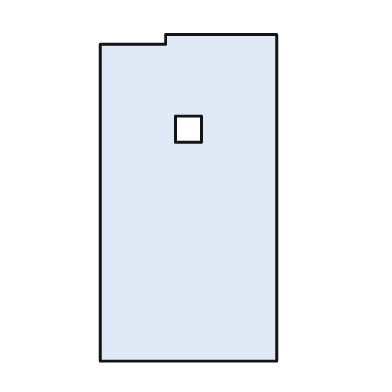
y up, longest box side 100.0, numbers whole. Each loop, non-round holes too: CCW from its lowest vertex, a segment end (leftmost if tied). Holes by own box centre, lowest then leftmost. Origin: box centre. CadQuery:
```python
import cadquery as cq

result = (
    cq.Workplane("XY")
    .moveTo(-27.0, -50.0)
    .lineTo(27.0, -50.0)
    .lineTo(27.0, 50.0)
    .lineTo(-7.0, 50.0)
    .lineTo(-7.0, 47.0)
    .lineTo(-27.0, 47.0)
    .close()
    .moveTo(-4.0, 17.0)
    .lineTo(4.0, 17.0)
    .lineTo(4.0, 25.0)
    .lineTo(-4.0, 25.0)
    .close()
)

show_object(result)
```